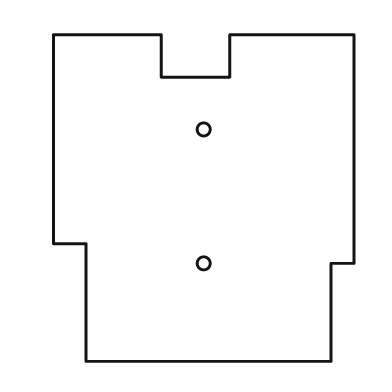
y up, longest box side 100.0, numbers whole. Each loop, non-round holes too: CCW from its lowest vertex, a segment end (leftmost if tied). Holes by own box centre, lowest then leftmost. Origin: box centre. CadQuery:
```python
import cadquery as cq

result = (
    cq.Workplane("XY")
    .moveTo(-36.0, -50.0)
    .lineTo(39.0, -50.0)
    .lineTo(39.0, -20.0)
    .lineTo(46.0, -20.0)
    .lineTo(46.0, 50.0)
    .lineTo(8.0, 50.0)
    .lineTo(8.0, 37.0)
    .lineTo(-13.0, 37.0)
    .lineTo(-13.0, 50.0)
    .lineTo(-46.0, 50.0)
    .lineTo(-46.0, -14.0)
    .lineTo(-36.0, -14.0)
    .close()
    .moveTo(0.0, -20.0)
    .circle(2.0)
    .moveTo(0.0, 21.0)
    .circle(2.0)
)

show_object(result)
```